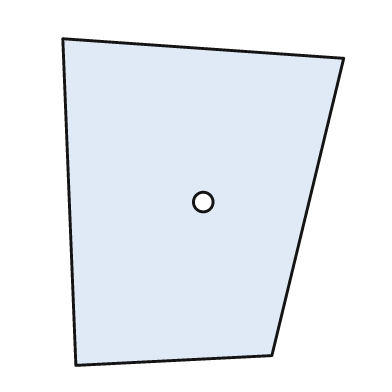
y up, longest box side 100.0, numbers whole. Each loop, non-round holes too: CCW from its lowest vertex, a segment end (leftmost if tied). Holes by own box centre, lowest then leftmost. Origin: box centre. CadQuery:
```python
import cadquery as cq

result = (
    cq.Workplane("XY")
    .moveTo(-39.0, -50.0)
    .lineTo(21.0, -47.0)
    .lineTo(43.0, 44.0)
    .lineTo(-43.0, 50.0)
    .close()
    .moveTo(0.0, 0.0)
    .circle(3.0)
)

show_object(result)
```